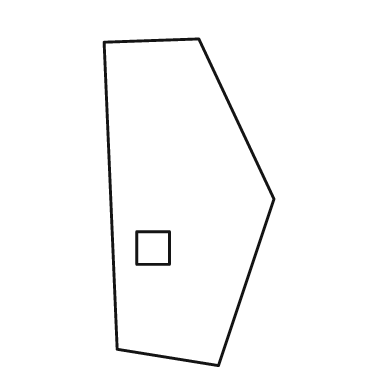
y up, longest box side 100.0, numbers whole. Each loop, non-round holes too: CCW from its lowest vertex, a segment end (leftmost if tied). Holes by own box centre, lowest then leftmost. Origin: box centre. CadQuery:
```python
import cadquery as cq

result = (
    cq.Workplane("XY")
    .moveTo(9.0, -50.0)
    .lineTo(26.0, 1.0)
    .lineTo(3.0, 50.0)
    .lineTo(-26.0, 49.0)
    .lineTo(-22.0, -45.0)
    .close()
    .moveTo(-16.0, -19.0)
    .lineTo(-6.0, -19.0)
    .lineTo(-6.0, -9.0)
    .lineTo(-16.0, -9.0)
    .close()
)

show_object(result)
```